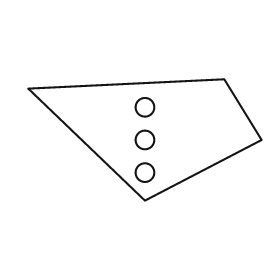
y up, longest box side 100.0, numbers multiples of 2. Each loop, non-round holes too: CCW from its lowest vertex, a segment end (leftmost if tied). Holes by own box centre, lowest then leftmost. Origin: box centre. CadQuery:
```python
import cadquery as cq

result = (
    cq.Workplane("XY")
    .moveTo(0.0, -26.0)
    .lineTo(50.0, 0.0)
    .lineTo(34.0, 26.0)
    .lineTo(-50.0, 22.0)
    .close()
    .moveTo(0.0, -14.0)
    .circle(4.0)
    .moveTo(0.0, 0.0)
    .circle(4.0)
    .moveTo(0.0, 14.0)
    .circle(4.0)
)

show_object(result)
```